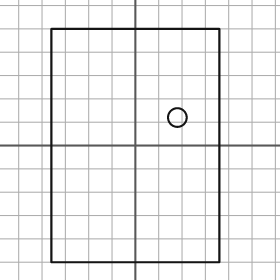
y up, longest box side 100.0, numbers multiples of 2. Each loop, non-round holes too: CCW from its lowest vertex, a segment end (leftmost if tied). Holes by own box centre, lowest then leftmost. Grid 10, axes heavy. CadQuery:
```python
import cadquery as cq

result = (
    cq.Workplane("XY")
    .moveTo(-36.0, -50.0)
    .lineTo(36.0, -50.0)
    .lineTo(36.0, 50.0)
    .lineTo(-36.0, 50.0)
    .close()
    .moveTo(18.0, 12.0)
    .circle(4.0)
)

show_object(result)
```